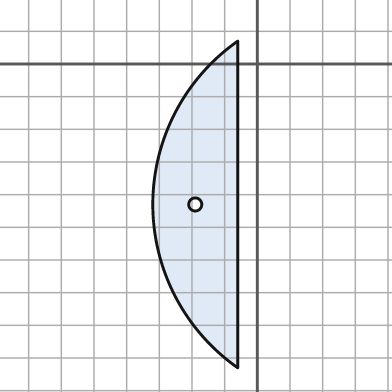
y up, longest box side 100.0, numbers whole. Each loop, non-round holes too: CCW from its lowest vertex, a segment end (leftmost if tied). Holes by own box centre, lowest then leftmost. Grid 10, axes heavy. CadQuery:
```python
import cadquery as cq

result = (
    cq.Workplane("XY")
    .moveTo(-6.0, -93.0)
    .lineTo(-6.0, 7.0)
    .threePointArc((-32.0, -43.0), (-6.0, -93.0))
    .close()
    .moveTo(-19.0, -43.0)
    .circle(2.0)
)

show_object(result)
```